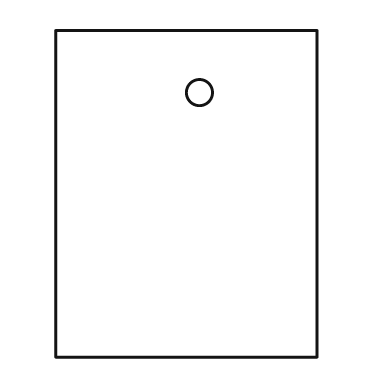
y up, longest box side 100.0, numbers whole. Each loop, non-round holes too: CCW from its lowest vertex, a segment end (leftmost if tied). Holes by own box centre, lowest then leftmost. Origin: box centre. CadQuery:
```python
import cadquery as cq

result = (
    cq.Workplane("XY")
    .moveTo(-40.0, -50.0)
    .lineTo(40.0, -50.0)
    .lineTo(40.0, 50.0)
    .lineTo(-40.0, 50.0)
    .close()
    .moveTo(4.0, 31.0)
    .circle(4.0)
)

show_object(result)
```